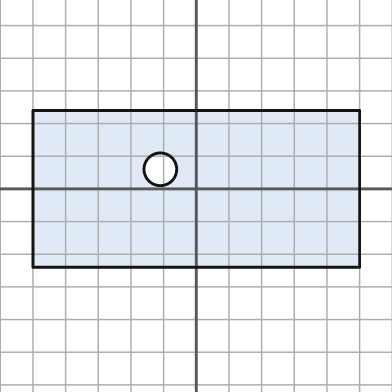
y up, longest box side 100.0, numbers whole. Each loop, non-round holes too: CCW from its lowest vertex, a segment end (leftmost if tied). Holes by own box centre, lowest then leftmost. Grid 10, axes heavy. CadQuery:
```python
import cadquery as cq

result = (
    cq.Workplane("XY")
    .moveTo(-50.0, -24.0)
    .lineTo(50.0, -24.0)
    .lineTo(50.0, 24.0)
    .lineTo(-50.0, 24.0)
    .close()
    .moveTo(-11.0, 6.0)
    .circle(5.0)
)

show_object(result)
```